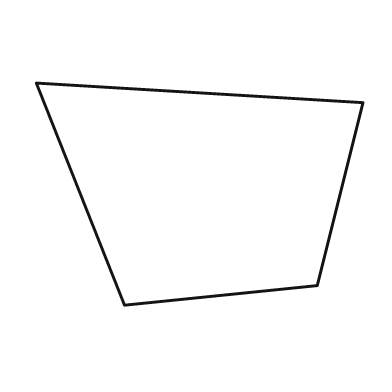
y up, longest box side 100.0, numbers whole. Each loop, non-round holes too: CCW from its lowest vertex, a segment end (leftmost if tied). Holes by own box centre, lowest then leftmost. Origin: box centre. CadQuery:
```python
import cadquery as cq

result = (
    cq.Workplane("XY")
    .moveTo(-23.0, -34.0)
    .lineTo(36.0, -28.0)
    .lineTo(50.0, 28.0)
    .lineTo(-50.0, 34.0)
    .close()
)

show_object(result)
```